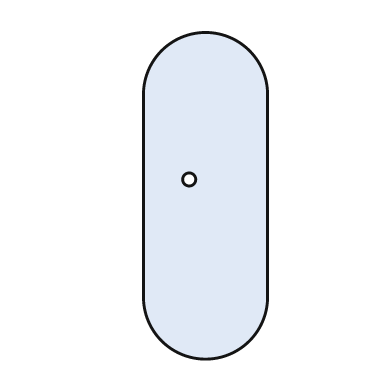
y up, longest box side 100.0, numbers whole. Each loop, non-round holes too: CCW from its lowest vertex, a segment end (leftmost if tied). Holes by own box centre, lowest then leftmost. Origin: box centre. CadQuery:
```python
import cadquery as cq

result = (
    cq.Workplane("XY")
    .moveTo(-19.0, -31.0)
    .threePointArc((0.0, -50.0), (19.0, -31.0))
    .lineTo(19.0, 31.0)
    .threePointArc((0.0, 50.0), (-19.0, 31.0))
    .close()
    .moveTo(-5.0, 5.0)
    .circle(2.0)
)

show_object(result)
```